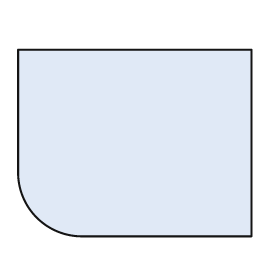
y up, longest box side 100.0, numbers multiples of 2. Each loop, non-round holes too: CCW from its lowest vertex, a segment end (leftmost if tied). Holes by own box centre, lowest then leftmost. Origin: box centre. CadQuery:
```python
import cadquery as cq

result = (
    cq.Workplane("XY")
    .moveTo(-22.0, -40.0)
    .lineTo(50.0, -40.0)
    .lineTo(50.0, 40.0)
    .lineTo(-50.0, 40.0)
    .lineTo(-50.0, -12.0)
    .threePointArc((-42.0, -32.0), (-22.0, -40.0))
    .close()
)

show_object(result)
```